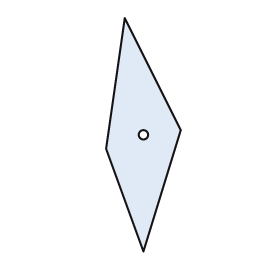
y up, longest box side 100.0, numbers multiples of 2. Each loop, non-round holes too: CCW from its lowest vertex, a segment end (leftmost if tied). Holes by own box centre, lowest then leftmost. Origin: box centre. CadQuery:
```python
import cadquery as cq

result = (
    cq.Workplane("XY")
    .moveTo(0.0, -50.0)
    .lineTo(16.0, 2.0)
    .lineTo(-8.0, 50.0)
    .lineTo(-16.0, -6.0)
    .close()
    .moveTo(0.0, 0.0)
    .circle(2.0)
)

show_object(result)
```